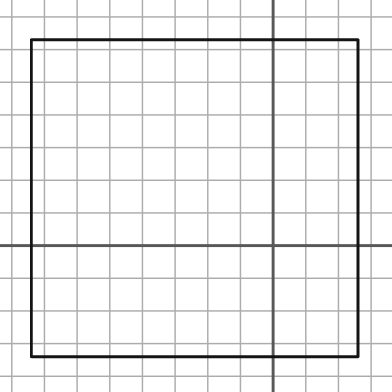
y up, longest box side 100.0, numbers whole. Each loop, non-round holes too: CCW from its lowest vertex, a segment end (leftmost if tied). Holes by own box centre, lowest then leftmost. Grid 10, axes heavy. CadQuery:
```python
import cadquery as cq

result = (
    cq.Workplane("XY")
    .moveTo(-74.0, -34.0)
    .lineTo(26.0, -34.0)
    .lineTo(26.0, 63.0)
    .lineTo(-74.0, 63.0)
    .close()
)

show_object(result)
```